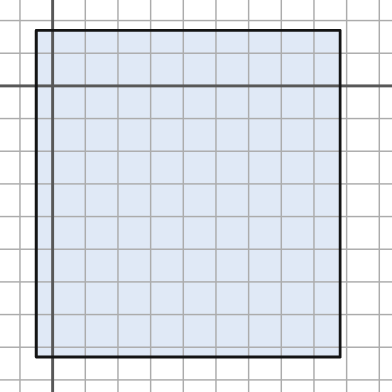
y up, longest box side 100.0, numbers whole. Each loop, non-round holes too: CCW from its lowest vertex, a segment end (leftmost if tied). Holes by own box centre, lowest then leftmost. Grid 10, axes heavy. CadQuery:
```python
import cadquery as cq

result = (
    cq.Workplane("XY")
    .moveTo(-5.0, -83.0)
    .lineTo(88.0, -83.0)
    .lineTo(88.0, 17.0)
    .lineTo(-5.0, 17.0)
    .close()
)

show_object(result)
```